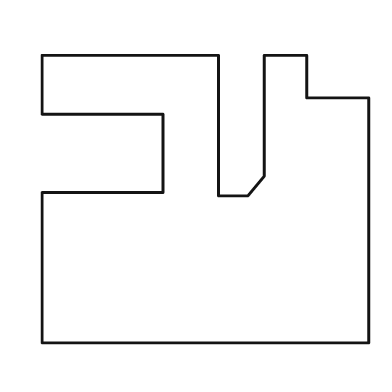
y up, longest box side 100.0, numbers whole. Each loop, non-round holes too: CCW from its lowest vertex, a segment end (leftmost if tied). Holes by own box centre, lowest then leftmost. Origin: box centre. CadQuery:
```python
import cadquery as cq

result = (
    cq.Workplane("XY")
    .moveTo(-50.0, -44.0)
    .lineTo(50.0, -44.0)
    .lineTo(50.0, 31.0)
    .lineTo(31.0, 31.0)
    .lineTo(31.0, 44.0)
    .lineTo(18.0, 44.0)
    .lineTo(18.0, 7.0)
    .lineTo(13.0, 1.0)
    .lineTo(4.0, 1.0)
    .lineTo(4.0, 44.0)
    .lineTo(-50.0, 44.0)
    .lineTo(-50.0, 26.0)
    .lineTo(-13.0, 26.0)
    .lineTo(-13.0, 2.0)
    .lineTo(-50.0, 2.0)
    .close()
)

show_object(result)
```